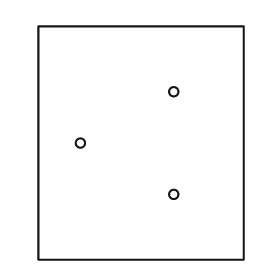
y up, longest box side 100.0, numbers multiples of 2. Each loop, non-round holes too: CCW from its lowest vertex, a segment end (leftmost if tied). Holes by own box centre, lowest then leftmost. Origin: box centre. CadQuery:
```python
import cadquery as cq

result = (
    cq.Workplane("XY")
    .moveTo(-44.0, -50.0)
    .lineTo(44.0, -50.0)
    .lineTo(44.0, 50.0)
    .lineTo(-44.0, 50.0)
    .close()
    .moveTo(14.0, -22.0)
    .circle(2.0)
    .moveTo(-26.0, 0.0)
    .circle(2.0)
    .moveTo(14.0, 22.0)
    .circle(2.0)
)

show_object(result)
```